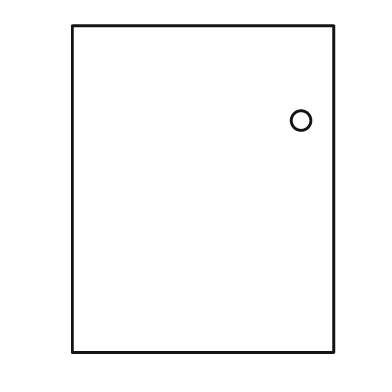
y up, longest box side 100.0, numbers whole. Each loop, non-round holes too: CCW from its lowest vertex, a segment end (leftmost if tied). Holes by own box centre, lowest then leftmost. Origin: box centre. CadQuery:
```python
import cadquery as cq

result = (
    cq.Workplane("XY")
    .moveTo(-40.0, -50.0)
    .lineTo(40.0, -50.0)
    .lineTo(40.0, 50.0)
    .lineTo(-40.0, 50.0)
    .close()
    .moveTo(30.0, 21.0)
    .circle(3.0)
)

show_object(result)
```